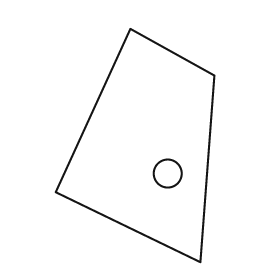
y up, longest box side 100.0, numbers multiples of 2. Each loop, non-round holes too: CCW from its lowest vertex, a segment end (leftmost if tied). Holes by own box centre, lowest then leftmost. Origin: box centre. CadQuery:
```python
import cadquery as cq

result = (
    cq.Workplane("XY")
    .moveTo(28.0, -50.0)
    .lineTo(34.0, 30.0)
    .lineTo(-2.0, 50.0)
    .lineTo(-34.0, -20.0)
    .close()
    .moveTo(14.0, -12.0)
    .circle(6.0)
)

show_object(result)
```